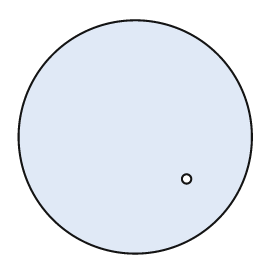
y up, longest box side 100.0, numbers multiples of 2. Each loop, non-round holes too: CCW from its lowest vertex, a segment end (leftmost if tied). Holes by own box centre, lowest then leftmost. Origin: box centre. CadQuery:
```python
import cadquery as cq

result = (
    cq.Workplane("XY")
    .moveTo(0.0, 0.0)
    .circle(50.0)
    .moveTo(22.0, -18.0)
    .circle(2.0)
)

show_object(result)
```